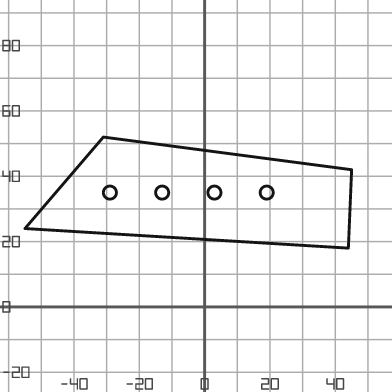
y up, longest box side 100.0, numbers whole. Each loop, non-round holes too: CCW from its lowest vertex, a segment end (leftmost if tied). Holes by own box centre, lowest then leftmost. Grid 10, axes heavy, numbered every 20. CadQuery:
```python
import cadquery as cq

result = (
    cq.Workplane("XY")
    .moveTo(44.0, 18.0)
    .lineTo(45.0, 42.0)
    .lineTo(-31.0, 52.0)
    .lineTo(-55.0, 24.0)
    .close()
    .moveTo(-29.0, 35.0)
    .circle(2.0)
    .moveTo(-13.0, 35.0)
    .circle(2.0)
    .moveTo(3.0, 35.0)
    .circle(2.0)
    .moveTo(19.0, 35.0)
    .circle(2.0)
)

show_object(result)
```